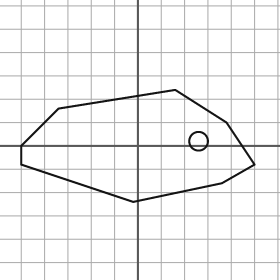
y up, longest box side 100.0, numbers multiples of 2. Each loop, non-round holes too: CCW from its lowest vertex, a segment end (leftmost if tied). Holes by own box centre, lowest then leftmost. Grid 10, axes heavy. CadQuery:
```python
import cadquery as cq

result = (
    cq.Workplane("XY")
    .moveTo(-2.0, -24.0)
    .lineTo(36.0, -16.0)
    .lineTo(50.0, -8.0)
    .lineTo(38.0, 10.0)
    .lineTo(16.0, 24.0)
    .lineTo(-34.0, 16.0)
    .lineTo(-50.0, 0.0)
    .lineTo(-50.0, -8.0)
    .close()
    .moveTo(26.0, 2.0)
    .circle(4.0)
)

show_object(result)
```